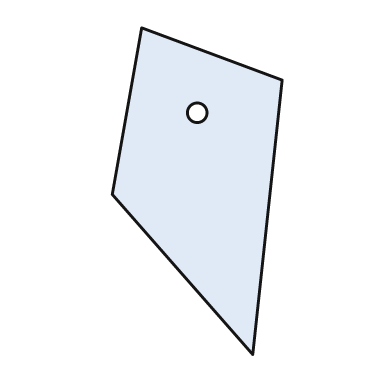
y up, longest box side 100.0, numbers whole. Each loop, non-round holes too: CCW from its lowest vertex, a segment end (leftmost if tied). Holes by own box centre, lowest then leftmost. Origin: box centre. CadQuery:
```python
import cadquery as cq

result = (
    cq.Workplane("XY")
    .moveTo(17.0, -50.0)
    .lineTo(26.0, 34.0)
    .lineTo(-17.0, 50.0)
    .lineTo(-26.0, -1.0)
    .close()
    .moveTo(0.0, 24.0)
    .circle(3.0)
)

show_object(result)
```